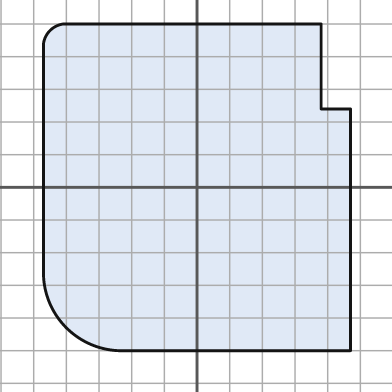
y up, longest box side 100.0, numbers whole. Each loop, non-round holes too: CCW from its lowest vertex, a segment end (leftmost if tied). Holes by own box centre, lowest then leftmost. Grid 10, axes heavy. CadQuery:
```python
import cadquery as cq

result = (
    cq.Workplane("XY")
    .moveTo(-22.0, -50.0)
    .lineTo(47.0, -50.0)
    .lineTo(47.0, 24.0)
    .lineTo(38.0, 24.0)
    .lineTo(38.0, 50.0)
    .lineTo(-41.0, 50.0)
    .threePointArc((-45.0, 48.0), (-47.0, 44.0))
    .lineTo(-47.0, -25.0)
    .threePointArc((-40.0, -43.0), (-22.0, -50.0))
    .close()
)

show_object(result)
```